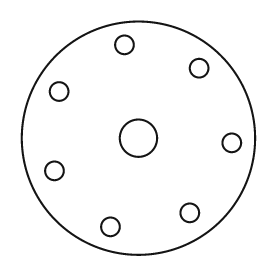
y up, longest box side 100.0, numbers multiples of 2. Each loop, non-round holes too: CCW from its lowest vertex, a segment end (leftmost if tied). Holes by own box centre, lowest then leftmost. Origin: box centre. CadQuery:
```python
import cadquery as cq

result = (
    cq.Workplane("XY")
    .moveTo(0.0, 0.0)
    .circle(50.0)
    .moveTo(-12.0, -38.0)
    .circle(4.0)
    .moveTo(22.0, -32.0)
    .circle(4.0)
    .moveTo(-36.0, -14.0)
    .circle(4.0)
    .moveTo(40.0, -2.0)
    .circle(4.0)
    .moveTo(0.0, 0.0)
    .circle(8.0)
    .moveTo(-34.0, 20.0)
    .circle(4.0)
    .moveTo(26.0, 30.0)
    .circle(4.0)
    .moveTo(-6.0, 40.0)
    .circle(4.0)
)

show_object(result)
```